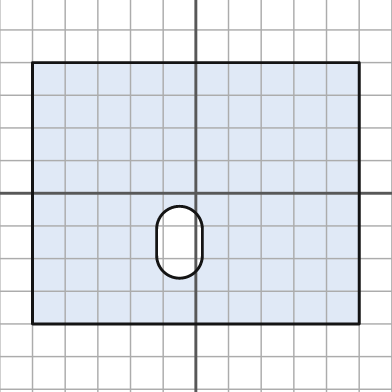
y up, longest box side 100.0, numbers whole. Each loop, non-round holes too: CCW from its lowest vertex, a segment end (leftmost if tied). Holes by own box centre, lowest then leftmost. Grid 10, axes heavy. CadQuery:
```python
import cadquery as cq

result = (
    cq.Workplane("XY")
    .moveTo(-50.0, -40.0)
    .lineTo(50.0, -40.0)
    .lineTo(50.0, 40.0)
    .lineTo(-50.0, 40.0)
    .close()
    .moveTo(-12.0, -19.0)
    .threePointArc((-5.0, -26.0), (2.0, -19.0))
    .lineTo(2.0, -11.0)
    .threePointArc((-5.0, -4.0), (-12.0, -11.0))
    .close()
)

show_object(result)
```